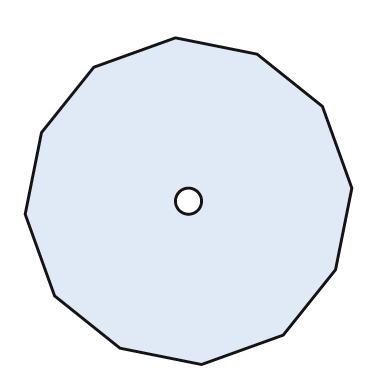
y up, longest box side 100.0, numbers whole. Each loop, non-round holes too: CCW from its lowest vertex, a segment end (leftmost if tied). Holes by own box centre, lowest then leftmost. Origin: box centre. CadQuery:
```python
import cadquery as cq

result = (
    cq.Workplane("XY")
    .moveTo(4.0, -50.0)
    .lineTo(29.0, -41.0)
    .lineTo(45.0, -21.0)
    .lineTo(50.0, 4.0)
    .lineTo(41.0, 29.0)
    .lineTo(21.0, 45.0)
    .lineTo(-4.0, 50.0)
    .lineTo(-29.0, 41.0)
    .lineTo(-45.0, 21.0)
    .lineTo(-50.0, -4.0)
    .lineTo(-41.0, -29.0)
    .lineTo(-21.0, -45.0)
    .close()
    .moveTo(0.0, 0.0)
    .circle(4.0)
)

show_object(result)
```